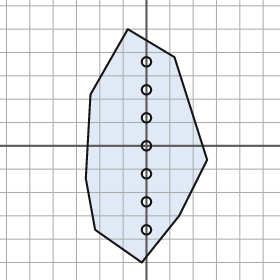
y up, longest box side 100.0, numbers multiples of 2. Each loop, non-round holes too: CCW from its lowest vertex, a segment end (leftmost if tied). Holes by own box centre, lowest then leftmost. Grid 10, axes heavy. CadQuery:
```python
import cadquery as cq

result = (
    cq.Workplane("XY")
    .moveTo(-2.0, -50.0)
    .lineTo(14.0, -30.0)
    .lineTo(26.0, -6.0)
    .lineTo(12.0, 38.0)
    .lineTo(-8.0, 50.0)
    .lineTo(-24.0, 22.0)
    .lineTo(-26.0, -14.0)
    .lineTo(-22.0, -36.0)
    .close()
    .moveTo(0.0, -36.0)
    .circle(2.0)
    .moveTo(0.0, -24.0)
    .circle(2.0)
    .moveTo(0.0, -12.0)
    .circle(2.0)
    .moveTo(0.0, 0.0)
    .circle(2.0)
    .moveTo(0.0, 12.0)
    .circle(2.0)
    .moveTo(0.0, 24.0)
    .circle(2.0)
    .moveTo(0.0, 36.0)
    .circle(2.0)
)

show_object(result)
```